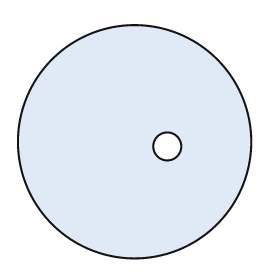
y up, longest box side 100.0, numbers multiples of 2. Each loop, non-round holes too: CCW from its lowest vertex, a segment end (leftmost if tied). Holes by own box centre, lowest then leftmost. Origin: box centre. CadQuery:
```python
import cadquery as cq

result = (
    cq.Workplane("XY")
    .moveTo(0.0, 0.0)
    .circle(50.0)
    .moveTo(14.0, -2.0)
    .circle(6.0)
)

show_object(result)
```